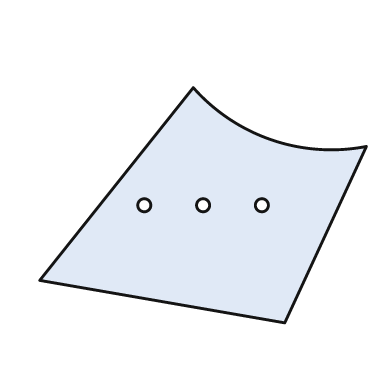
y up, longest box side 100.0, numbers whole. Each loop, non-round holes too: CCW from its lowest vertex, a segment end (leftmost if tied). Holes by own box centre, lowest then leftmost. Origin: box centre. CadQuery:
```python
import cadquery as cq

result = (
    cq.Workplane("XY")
    .moveTo(25.0, -36.0)
    .lineTo(50.0, 18.0)
    .threePointArc((21.0, 20.0), (-3.0, 36.0))
    .lineTo(-50.0, -23.0)
    .close()
    .moveTo(-18.0, 0.0)
    .circle(2.0)
    .moveTo(0.0, 0.0)
    .circle(2.0)
    .moveTo(18.0, 0.0)
    .circle(2.0)
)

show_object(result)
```